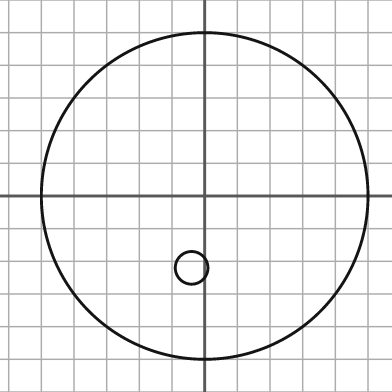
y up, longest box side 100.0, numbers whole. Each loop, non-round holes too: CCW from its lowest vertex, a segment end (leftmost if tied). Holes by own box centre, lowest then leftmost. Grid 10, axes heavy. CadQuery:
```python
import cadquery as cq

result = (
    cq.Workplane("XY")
    .moveTo(0.0, 0.0)
    .circle(50.0)
    .moveTo(-4.0, -22.0)
    .circle(5.0)
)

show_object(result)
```